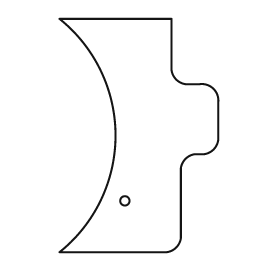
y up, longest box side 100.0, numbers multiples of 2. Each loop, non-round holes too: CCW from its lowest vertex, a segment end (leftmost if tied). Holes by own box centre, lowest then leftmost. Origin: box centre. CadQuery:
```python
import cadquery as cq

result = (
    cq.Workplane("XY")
    .moveTo(-34.0, -50.0)
    .lineTo(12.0, -50.0)
    .threePointArc((16.0, -48.0), (18.0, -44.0))
    .lineTo(18.0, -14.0)
    .threePointArc((20.0, -10.0), (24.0, -8.0))
    .lineTo(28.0, -8.0)
    .threePointArc((32.0, -6.0), (34.0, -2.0))
    .lineTo(34.0, 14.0)
    .threePointArc((32.0, 20.0), (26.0, 22.0))
    .lineTo(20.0, 22.0)
    .threePointArc((16.0, 24.0), (14.0, 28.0))
    .lineTo(14.0, 50.0)
    .lineTo(-34.0, 50.0)
    .threePointArc((-10.0, 0.0), (-34.0, -50.0))
    .close()
    .moveTo(-6.0, -28.0)
    .circle(2.0)
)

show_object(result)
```